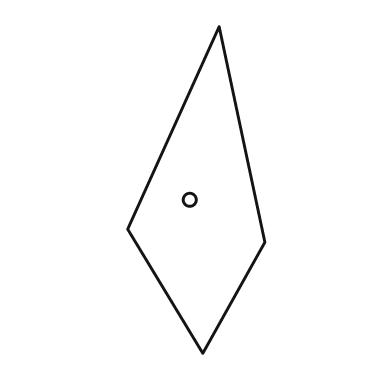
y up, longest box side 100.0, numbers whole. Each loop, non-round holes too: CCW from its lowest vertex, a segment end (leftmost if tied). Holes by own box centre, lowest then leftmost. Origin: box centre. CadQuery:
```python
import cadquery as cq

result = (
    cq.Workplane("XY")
    .moveTo(2.0, -50.0)
    .lineTo(21.0, -16.0)
    .lineTo(7.0, 50.0)
    .lineTo(-21.0, -12.0)
    .close()
    .moveTo(-2.0, -3.0)
    .circle(2.0)
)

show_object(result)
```